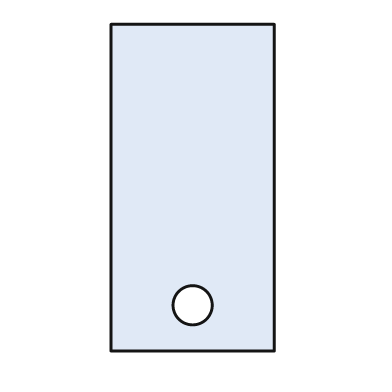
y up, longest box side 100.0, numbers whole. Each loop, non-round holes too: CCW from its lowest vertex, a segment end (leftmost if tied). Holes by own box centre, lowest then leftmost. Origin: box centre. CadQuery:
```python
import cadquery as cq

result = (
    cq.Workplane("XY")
    .moveTo(-25.0, -50.0)
    .lineTo(25.0, -50.0)
    .lineTo(25.0, 50.0)
    .lineTo(-25.0, 50.0)
    .close()
    .moveTo(0.0, -36.0)
    .circle(6.0)
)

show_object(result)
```